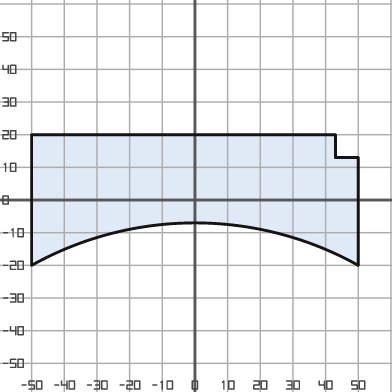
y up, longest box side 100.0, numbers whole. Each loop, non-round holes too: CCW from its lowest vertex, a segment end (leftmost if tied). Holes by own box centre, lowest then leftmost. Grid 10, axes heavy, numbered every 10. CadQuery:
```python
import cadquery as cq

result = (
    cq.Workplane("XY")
    .moveTo(-50.0, -20.0)
    .threePointArc((0.0, -7.0), (50.0, -20.0))
    .lineTo(50.0, 13.0)
    .lineTo(43.0, 13.0)
    .lineTo(43.0, 20.0)
    .lineTo(-50.0, 20.0)
    .close()
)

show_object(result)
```